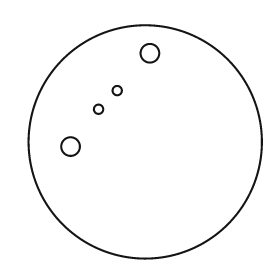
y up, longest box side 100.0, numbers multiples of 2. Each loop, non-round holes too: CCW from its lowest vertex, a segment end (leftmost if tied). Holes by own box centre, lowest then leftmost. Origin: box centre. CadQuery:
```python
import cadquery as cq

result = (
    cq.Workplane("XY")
    .moveTo(0.0, 0.0)
    .circle(50.0)
    .moveTo(-32.0, -2.0)
    .circle(4.0)
    .moveTo(-20.0, 14.0)
    .circle(2.0)
    .moveTo(-12.0, 22.0)
    .circle(2.0)
    .moveTo(2.0, 38.0)
    .circle(4.0)
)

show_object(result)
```